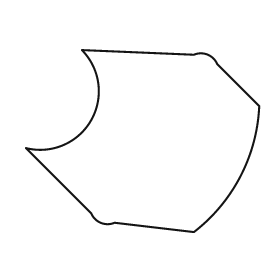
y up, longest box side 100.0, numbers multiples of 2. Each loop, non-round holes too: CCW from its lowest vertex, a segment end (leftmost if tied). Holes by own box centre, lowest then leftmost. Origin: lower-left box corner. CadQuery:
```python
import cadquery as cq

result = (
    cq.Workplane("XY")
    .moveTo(72.0, 0.0)
    .threePointArc((92.0, 24.0), (100.0, 54.0))
    .lineTo(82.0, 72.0)
    .threePointArc((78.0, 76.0), (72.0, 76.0))
    .lineTo(24.0, 78.0)
    .threePointArc((28.0, 48.0), (0.0, 36.0))
    .lineTo(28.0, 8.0)
    .threePointArc((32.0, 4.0), (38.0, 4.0))
    .close()
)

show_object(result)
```